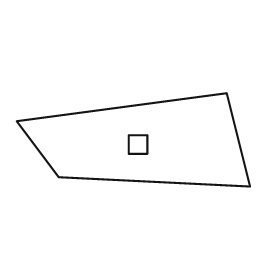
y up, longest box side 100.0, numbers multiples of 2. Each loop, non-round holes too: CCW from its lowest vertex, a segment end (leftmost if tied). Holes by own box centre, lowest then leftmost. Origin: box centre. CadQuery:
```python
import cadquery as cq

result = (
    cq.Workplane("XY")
    .moveTo(50.0, -20.0)
    .lineTo(40.0, 20.0)
    .lineTo(-50.0, 8.0)
    .lineTo(-32.0, -16.0)
    .close()
    .moveTo(-2.0, -6.0)
    .lineTo(6.0, -6.0)
    .lineTo(6.0, 2.0)
    .lineTo(-2.0, 2.0)
    .close()
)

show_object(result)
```